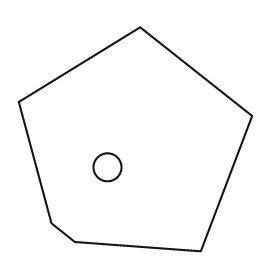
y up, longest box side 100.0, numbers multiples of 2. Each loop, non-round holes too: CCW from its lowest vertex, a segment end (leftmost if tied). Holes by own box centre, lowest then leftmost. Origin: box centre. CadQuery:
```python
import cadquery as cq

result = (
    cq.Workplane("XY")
    .moveTo(28.0, -48.0)
    .lineTo(50.0, 10.0)
    .lineTo(2.0, 48.0)
    .lineTo(-50.0, 16.0)
    .lineTo(-36.0, -36.0)
    .lineTo(-26.0, -44.0)
    .close()
    .moveTo(-12.0, -12.0)
    .circle(6.0)
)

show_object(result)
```